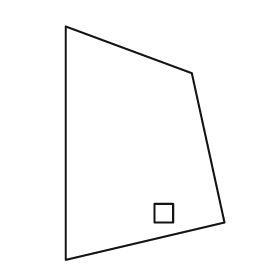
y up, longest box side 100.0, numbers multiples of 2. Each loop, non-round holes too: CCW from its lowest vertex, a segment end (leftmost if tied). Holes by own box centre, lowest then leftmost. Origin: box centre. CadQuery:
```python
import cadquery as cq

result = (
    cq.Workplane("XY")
    .moveTo(-34.0, -50.0)
    .lineTo(34.0, -34.0)
    .lineTo(20.0, 30.0)
    .lineTo(-34.0, 50.0)
    .close()
    .moveTo(4.0, -34.0)
    .lineTo(12.0, -34.0)
    .lineTo(12.0, -26.0)
    .lineTo(4.0, -26.0)
    .close()
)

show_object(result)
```